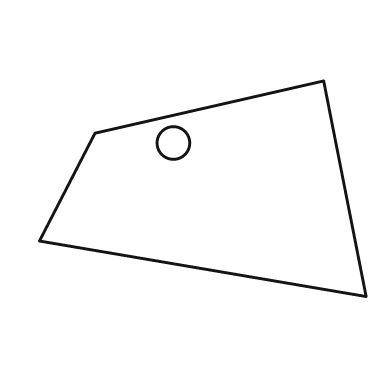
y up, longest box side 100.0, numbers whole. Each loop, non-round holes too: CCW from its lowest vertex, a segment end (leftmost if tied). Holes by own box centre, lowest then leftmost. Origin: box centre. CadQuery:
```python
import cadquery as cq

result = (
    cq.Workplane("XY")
    .moveTo(50.0, -33.0)
    .lineTo(37.0, 33.0)
    .lineTo(-33.0, 17.0)
    .lineTo(-50.0, -16.0)
    .close()
    .moveTo(-9.0, 14.0)
    .circle(5.0)
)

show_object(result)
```